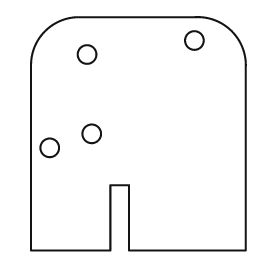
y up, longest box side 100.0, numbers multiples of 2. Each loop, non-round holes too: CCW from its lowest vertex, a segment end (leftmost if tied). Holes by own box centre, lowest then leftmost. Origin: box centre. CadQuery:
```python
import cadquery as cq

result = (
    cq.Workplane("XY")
    .moveTo(-46.0, -50.0)
    .lineTo(-12.0, -50.0)
    .lineTo(-12.0, -22.0)
    .lineTo(-4.0, -22.0)
    .lineTo(-4.0, -50.0)
    .lineTo(46.0, -50.0)
    .lineTo(46.0, 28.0)
    .threePointArc((40.0, 44.0), (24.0, 50.0))
    .lineTo(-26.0, 50.0)
    .threePointArc((-40.0, 44.0), (-46.0, 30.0))
    .close()
    .moveTo(-38.0, -6.0)
    .circle(4.0)
    .moveTo(-20.0, 0.0)
    .circle(4.0)
    .moveTo(-22.0, 34.0)
    .circle(4.0)
    .moveTo(24.0, 40.0)
    .circle(4.0)
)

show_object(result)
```